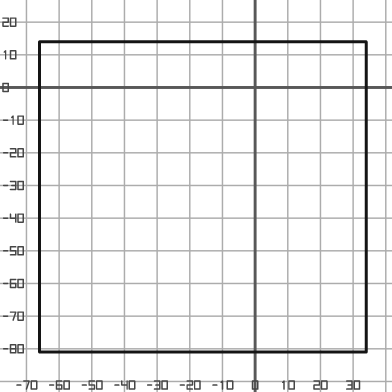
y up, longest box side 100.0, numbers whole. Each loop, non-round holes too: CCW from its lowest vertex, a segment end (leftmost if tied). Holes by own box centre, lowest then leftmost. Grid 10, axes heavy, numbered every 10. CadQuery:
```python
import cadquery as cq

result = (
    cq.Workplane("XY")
    .moveTo(-66.0, -81.0)
    .lineTo(34.0, -81.0)
    .lineTo(34.0, 14.0)
    .lineTo(-66.0, 14.0)
    .close()
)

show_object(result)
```